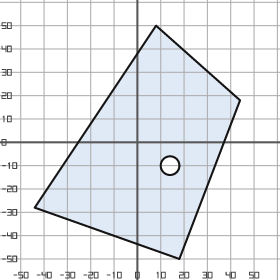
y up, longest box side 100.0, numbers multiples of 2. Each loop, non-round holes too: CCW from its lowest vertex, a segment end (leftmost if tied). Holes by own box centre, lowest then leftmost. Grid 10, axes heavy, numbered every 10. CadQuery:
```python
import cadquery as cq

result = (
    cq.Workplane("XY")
    .moveTo(18.0, -50.0)
    .lineTo(44.0, 18.0)
    .lineTo(8.0, 50.0)
    .lineTo(-44.0, -28.0)
    .close()
    .moveTo(14.0, -10.0)
    .circle(4.0)
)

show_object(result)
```